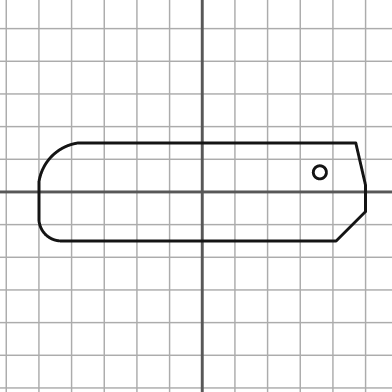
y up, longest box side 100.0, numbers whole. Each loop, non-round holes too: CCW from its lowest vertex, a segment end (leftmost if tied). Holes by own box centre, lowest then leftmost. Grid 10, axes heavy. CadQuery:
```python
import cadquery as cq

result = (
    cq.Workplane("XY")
    .moveTo(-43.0, -15.0)
    .lineTo(41.0, -15.0)
    .lineTo(50.0, -6.0)
    .lineTo(50.0, 2.0)
    .lineTo(47.0, 15.0)
    .lineTo(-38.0, 15.0)
    .threePointArc((-46.0, 11.0), (-50.0, 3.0))
    .lineTo(-50.0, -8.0)
    .threePointArc((-48.0, -13.0), (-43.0, -15.0))
    .close()
    .moveTo(36.0, 6.0)
    .circle(2.0)
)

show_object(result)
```